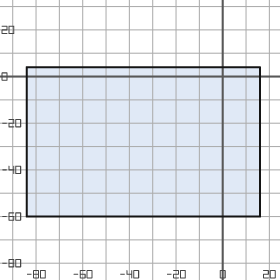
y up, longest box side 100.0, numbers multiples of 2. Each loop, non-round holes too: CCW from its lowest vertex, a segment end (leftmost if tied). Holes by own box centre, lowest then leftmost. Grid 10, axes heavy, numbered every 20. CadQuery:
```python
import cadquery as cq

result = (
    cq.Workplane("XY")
    .moveTo(-84.0, -60.0)
    .lineTo(16.0, -60.0)
    .lineTo(16.0, 4.0)
    .lineTo(-84.0, 4.0)
    .close()
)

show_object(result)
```